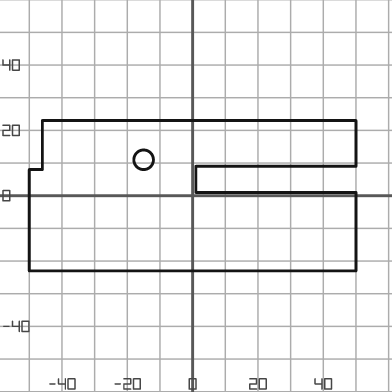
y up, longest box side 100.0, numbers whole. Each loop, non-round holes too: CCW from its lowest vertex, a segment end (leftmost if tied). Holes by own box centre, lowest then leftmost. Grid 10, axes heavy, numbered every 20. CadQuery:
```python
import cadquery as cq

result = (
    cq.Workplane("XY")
    .moveTo(-50.0, -23.0)
    .lineTo(50.0, -23.0)
    .lineTo(50.0, 1.0)
    .lineTo(1.0, 1.0)
    .lineTo(1.0, 9.0)
    .lineTo(50.0, 9.0)
    .lineTo(50.0, 23.0)
    .lineTo(-46.0, 23.0)
    .lineTo(-46.0, 8.0)
    .lineTo(-50.0, 8.0)
    .close()
    .moveTo(-15.0, 11.0)
    .circle(3.0)
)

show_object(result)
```